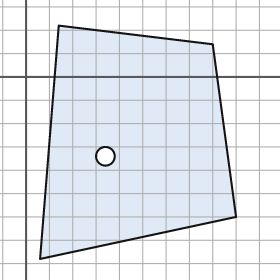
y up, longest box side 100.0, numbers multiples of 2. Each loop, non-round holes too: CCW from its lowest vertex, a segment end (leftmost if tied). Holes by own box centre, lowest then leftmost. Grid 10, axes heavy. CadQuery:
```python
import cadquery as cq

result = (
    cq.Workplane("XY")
    .moveTo(6.0, -78.0)
    .lineTo(90.0, -60.0)
    .lineTo(80.0, 14.0)
    .lineTo(14.0, 22.0)
    .close()
    .moveTo(34.0, -34.0)
    .circle(4.0)
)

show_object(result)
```